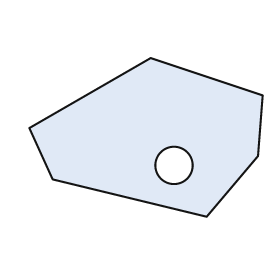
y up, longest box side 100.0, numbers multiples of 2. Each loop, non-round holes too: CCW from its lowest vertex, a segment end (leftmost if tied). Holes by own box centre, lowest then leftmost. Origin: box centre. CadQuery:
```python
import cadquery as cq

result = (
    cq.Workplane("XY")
    .moveTo(26.0, -34.0)
    .lineTo(48.0, -8.0)
    .lineTo(50.0, 18.0)
    .lineTo(2.0, 34.0)
    .lineTo(-50.0, 4.0)
    .lineTo(-40.0, -18.0)
    .close()
    .moveTo(12.0, -12.0)
    .circle(8.0)
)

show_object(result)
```